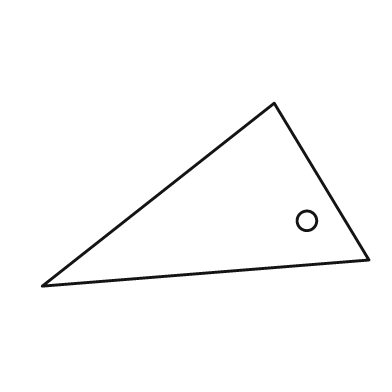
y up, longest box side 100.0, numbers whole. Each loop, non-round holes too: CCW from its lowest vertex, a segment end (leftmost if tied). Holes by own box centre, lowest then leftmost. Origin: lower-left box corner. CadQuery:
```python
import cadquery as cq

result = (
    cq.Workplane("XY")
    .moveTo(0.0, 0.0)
    .lineTo(100.0, 8.0)
    .lineTo(71.0, 56.0)
    .close()
    .moveTo(81.0, 20.0)
    .circle(3.0)
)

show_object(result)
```